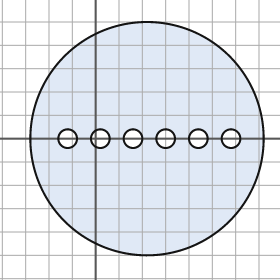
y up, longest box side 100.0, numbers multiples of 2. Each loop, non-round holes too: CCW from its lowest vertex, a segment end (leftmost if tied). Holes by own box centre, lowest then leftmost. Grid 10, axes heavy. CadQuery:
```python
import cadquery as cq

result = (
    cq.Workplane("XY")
    .moveTo(22.0, 0.0)
    .circle(50.0)
    .moveTo(-12.0, 0.0)
    .circle(4.0)
    .moveTo(2.0, 0.0)
    .circle(4.0)
    .moveTo(16.0, 0.0)
    .circle(4.0)
    .moveTo(30.0, 0.0)
    .circle(4.0)
    .moveTo(44.0, 0.0)
    .circle(4.0)
    .moveTo(58.0, 0.0)
    .circle(4.0)
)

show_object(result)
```